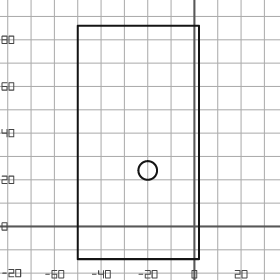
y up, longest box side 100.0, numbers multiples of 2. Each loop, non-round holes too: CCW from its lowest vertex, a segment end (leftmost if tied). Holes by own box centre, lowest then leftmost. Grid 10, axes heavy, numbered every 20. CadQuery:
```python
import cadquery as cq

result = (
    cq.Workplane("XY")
    .moveTo(-50.0, -14.0)
    .lineTo(2.0, -14.0)
    .lineTo(2.0, 86.0)
    .lineTo(-50.0, 86.0)
    .close()
    .moveTo(-20.0, 24.0)
    .circle(4.0)
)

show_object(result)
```